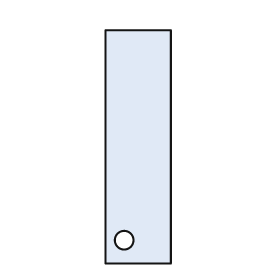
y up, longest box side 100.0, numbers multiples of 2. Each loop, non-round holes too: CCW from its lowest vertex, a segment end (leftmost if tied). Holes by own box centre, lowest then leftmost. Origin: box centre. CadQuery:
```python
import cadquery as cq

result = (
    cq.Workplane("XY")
    .moveTo(-14.0, -50.0)
    .lineTo(14.0, -50.0)
    .lineTo(14.0, 50.0)
    .lineTo(-14.0, 50.0)
    .close()
    .moveTo(-6.0, -40.0)
    .circle(4.0)
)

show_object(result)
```